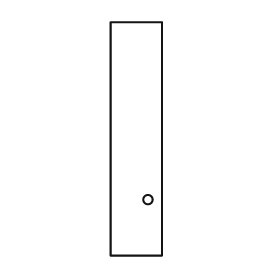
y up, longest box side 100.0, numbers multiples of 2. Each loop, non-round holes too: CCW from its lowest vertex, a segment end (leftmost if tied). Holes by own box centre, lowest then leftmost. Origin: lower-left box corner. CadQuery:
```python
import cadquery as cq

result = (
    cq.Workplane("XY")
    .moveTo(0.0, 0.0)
    .lineTo(22.0, 0.0)
    .lineTo(22.0, 100.0)
    .lineTo(0.0, 100.0)
    .close()
    .moveTo(16.0, 24.0)
    .circle(2.0)
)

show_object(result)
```